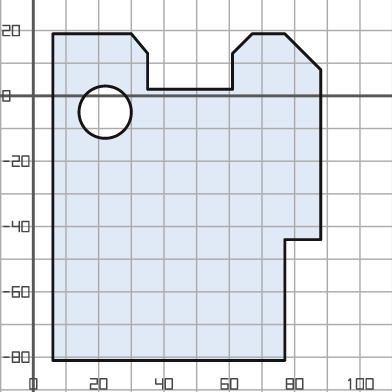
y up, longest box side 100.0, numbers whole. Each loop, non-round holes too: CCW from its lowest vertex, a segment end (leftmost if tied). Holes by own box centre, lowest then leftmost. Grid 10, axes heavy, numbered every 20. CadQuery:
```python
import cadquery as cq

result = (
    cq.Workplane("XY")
    .moveTo(6.0, -81.0)
    .lineTo(77.0, -81.0)
    .lineTo(77.0, -44.0)
    .lineTo(88.0, -44.0)
    .lineTo(88.0, 8.0)
    .lineTo(77.0, 19.0)
    .lineTo(67.0, 19.0)
    .lineTo(61.0, 13.0)
    .lineTo(61.0, 2.0)
    .lineTo(35.0, 2.0)
    .lineTo(35.0, 13.0)
    .lineTo(30.0, 19.0)
    .lineTo(6.0, 19.0)
    .close()
    .moveTo(22.0, -5.0)
    .circle(8.0)
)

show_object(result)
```